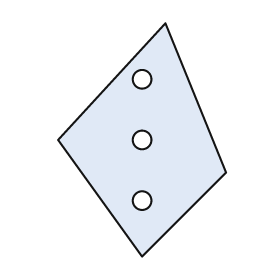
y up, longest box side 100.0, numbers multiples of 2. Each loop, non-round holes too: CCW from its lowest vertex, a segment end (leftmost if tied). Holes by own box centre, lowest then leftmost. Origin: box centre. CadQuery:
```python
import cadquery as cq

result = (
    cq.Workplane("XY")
    .moveTo(0.0, -50.0)
    .lineTo(36.0, -14.0)
    .lineTo(10.0, 50.0)
    .lineTo(-36.0, 0.0)
    .close()
    .moveTo(0.0, -26.0)
    .circle(4.0)
    .moveTo(0.0, 0.0)
    .circle(4.0)
    .moveTo(0.0, 26.0)
    .circle(4.0)
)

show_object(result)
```